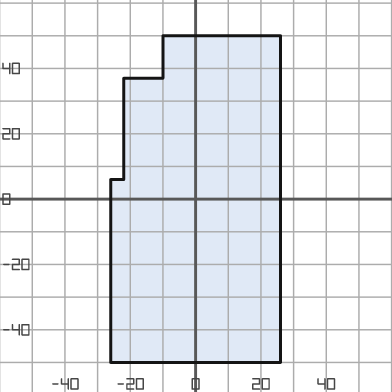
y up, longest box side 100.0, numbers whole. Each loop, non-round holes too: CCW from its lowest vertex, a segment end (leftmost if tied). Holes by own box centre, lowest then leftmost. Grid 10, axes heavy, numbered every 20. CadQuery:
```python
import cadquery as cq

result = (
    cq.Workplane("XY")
    .moveTo(-26.0, -50.0)
    .lineTo(26.0, -50.0)
    .lineTo(26.0, 50.0)
    .lineTo(-10.0, 50.0)
    .lineTo(-10.0, 37.0)
    .lineTo(-22.0, 37.0)
    .lineTo(-22.0, 6.0)
    .lineTo(-26.0, 6.0)
    .close()
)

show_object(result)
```